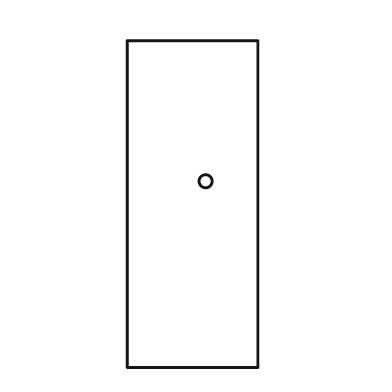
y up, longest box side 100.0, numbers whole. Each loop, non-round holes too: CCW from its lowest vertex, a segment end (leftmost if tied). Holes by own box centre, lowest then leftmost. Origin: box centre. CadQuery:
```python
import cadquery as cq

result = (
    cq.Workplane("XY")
    .moveTo(-20.0, -50.0)
    .lineTo(20.0, -50.0)
    .lineTo(20.0, 50.0)
    .lineTo(-20.0, 50.0)
    .close()
    .moveTo(4.0, 7.0)
    .circle(2.0)
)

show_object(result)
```